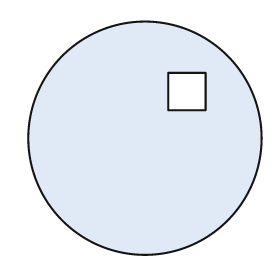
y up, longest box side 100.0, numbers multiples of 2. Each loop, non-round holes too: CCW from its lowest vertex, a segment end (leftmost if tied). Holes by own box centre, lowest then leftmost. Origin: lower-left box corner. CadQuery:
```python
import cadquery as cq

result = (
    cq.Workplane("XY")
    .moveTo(50.0, 50.0)
    .circle(50.0)
    .moveTo(60.0, 62.0)
    .lineTo(76.0, 62.0)
    .lineTo(76.0, 78.0)
    .lineTo(60.0, 78.0)
    .close()
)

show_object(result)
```